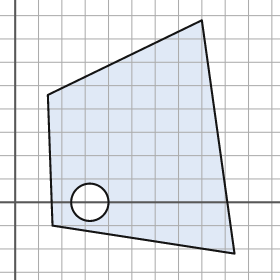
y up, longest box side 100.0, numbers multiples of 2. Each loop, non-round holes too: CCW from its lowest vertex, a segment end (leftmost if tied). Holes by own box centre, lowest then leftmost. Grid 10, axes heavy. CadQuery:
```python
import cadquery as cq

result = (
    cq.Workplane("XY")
    .moveTo(94.0, -22.0)
    .lineTo(80.0, 78.0)
    .lineTo(14.0, 46.0)
    .lineTo(16.0, -10.0)
    .close()
    .moveTo(32.0, 0.0)
    .circle(8.0)
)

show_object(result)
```